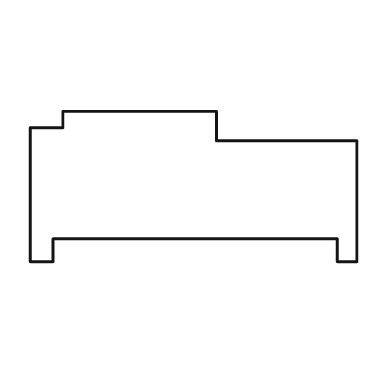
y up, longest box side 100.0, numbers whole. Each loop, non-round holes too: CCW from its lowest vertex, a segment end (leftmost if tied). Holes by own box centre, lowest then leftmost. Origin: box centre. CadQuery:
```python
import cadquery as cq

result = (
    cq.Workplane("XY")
    .moveTo(-50.0, -23.0)
    .lineTo(-43.0, -23.0)
    .lineTo(-43.0, -16.0)
    .lineTo(44.0, -16.0)
    .lineTo(44.0, -23.0)
    .lineTo(50.0, -23.0)
    .lineTo(50.0, 14.0)
    .lineTo(7.0, 14.0)
    .lineTo(7.0, 23.0)
    .lineTo(-40.0, 23.0)
    .lineTo(-40.0, 18.0)
    .lineTo(-50.0, 18.0)
    .close()
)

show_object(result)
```